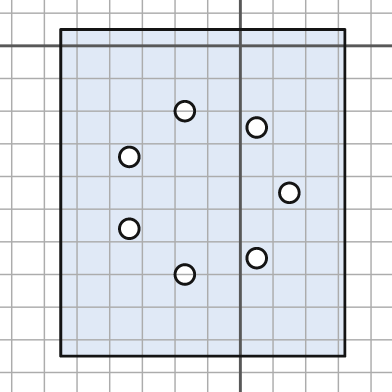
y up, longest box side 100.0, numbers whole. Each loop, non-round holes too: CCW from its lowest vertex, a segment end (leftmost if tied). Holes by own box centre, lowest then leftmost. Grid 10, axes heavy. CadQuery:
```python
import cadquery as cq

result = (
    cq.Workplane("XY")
    .moveTo(-55.0, -95.0)
    .lineTo(32.0, -95.0)
    .lineTo(32.0, 5.0)
    .lineTo(-55.0, 5.0)
    .close()
    .moveTo(-17.0, -70.0)
    .circle(3.0)
    .moveTo(5.0, -65.0)
    .circle(3.0)
    .moveTo(-34.0, -56.0)
    .circle(3.0)
    .moveTo(15.0, -45.0)
    .circle(3.0)
    .moveTo(-34.0, -34.0)
    .circle(3.0)
    .moveTo(5.0, -25.0)
    .circle(3.0)
    .moveTo(-17.0, -20.0)
    .circle(3.0)
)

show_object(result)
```